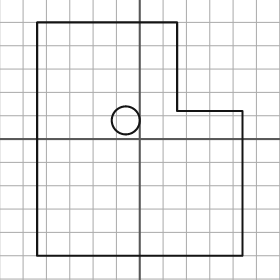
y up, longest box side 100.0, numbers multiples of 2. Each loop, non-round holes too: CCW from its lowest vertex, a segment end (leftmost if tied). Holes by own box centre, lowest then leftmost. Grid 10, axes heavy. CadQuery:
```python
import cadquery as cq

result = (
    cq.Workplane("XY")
    .moveTo(-44.0, -50.0)
    .lineTo(44.0, -50.0)
    .lineTo(44.0, 12.0)
    .lineTo(16.0, 12.0)
    .lineTo(16.0, 50.0)
    .lineTo(-44.0, 50.0)
    .close()
    .moveTo(-6.0, 8.0)
    .circle(6.0)
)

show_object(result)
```